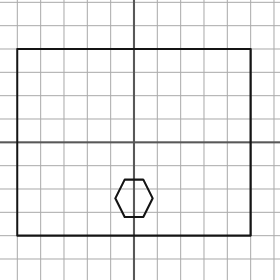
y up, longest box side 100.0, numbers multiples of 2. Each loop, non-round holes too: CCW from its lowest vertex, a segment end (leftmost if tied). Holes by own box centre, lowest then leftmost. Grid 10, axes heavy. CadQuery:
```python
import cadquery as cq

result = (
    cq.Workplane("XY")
    .moveTo(-50.0, -40.0)
    .lineTo(50.0, -40.0)
    .lineTo(50.0, 40.0)
    .lineTo(-50.0, 40.0)
    .close()
    .moveTo(-4.0, -32.0)
    .lineTo(4.0, -32.0)
    .lineTo(8.0, -24.0)
    .lineTo(4.0, -16.0)
    .lineTo(-4.0, -16.0)
    .lineTo(-8.0, -24.0)
    .close()
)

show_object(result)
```